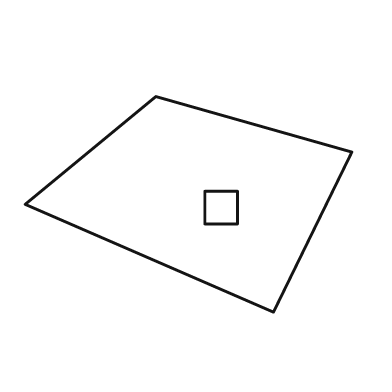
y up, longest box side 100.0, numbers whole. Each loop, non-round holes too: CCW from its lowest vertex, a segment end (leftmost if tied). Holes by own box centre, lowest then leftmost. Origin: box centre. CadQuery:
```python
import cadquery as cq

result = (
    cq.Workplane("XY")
    .moveTo(26.0, -33.0)
    .lineTo(50.0, 16.0)
    .lineTo(-10.0, 33.0)
    .lineTo(-50.0, 0.0)
    .close()
    .moveTo(5.0, -6.0)
    .lineTo(15.0, -6.0)
    .lineTo(15.0, 4.0)
    .lineTo(5.0, 4.0)
    .close()
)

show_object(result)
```